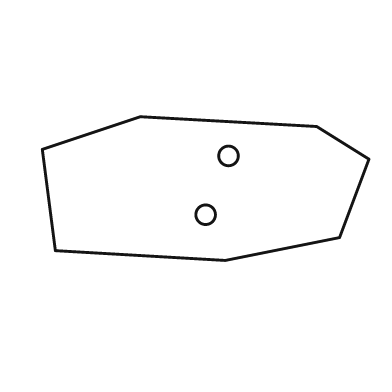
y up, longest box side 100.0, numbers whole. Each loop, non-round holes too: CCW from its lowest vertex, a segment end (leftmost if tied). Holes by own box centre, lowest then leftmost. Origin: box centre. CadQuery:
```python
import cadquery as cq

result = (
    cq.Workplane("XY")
    .moveTo(6.0, -22.0)
    .lineTo(41.0, -15.0)
    .lineTo(50.0, 9.0)
    .lineTo(34.0, 19.0)
    .lineTo(-20.0, 22.0)
    .lineTo(-50.0, 12.0)
    .lineTo(-46.0, -19.0)
    .close()
    .moveTo(0.0, -8.0)
    .circle(3.0)
    .moveTo(7.0, 10.0)
    .circle(3.0)
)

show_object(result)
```